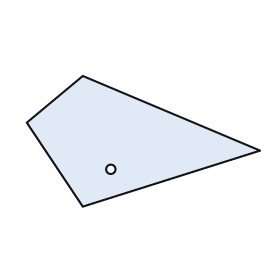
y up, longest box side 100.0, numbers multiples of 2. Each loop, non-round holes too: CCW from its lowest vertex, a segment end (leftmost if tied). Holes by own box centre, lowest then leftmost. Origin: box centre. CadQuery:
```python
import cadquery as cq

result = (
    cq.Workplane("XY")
    .moveTo(-26.0, -28.0)
    .lineTo(50.0, -4.0)
    .lineTo(-26.0, 28.0)
    .lineTo(-50.0, 8.0)
    .close()
    .moveTo(-14.0, -12.0)
    .circle(2.0)
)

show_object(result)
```